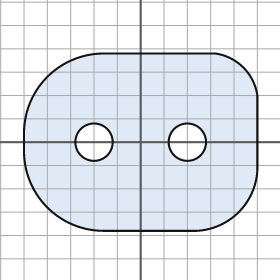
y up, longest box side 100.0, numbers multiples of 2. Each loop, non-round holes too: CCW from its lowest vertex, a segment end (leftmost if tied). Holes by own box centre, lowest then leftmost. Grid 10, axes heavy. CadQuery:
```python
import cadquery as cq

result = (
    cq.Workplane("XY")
    .moveTo(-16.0, -38.0)
    .lineTo(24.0, -38.0)
    .threePointArc((42.0, -30.0), (50.0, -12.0))
    .lineTo(50.0, 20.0)
    .threePointArc((44.0, 32.0), (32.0, 38.0))
    .lineTo(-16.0, 38.0)
    .threePointArc((-40.0, 28.0), (-50.0, 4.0))
    .lineTo(-50.0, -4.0)
    .threePointArc((-40.0, -28.0), (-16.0, -38.0))
    .close()
    .moveTo(-20.0, 0.0)
    .circle(8.0)
    .moveTo(20.0, 0.0)
    .circle(8.0)
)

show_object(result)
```